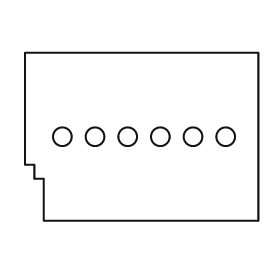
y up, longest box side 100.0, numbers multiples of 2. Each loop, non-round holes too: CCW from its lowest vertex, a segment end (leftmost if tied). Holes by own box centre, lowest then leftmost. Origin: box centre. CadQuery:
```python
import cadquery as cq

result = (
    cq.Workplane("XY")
    .moveTo(-42.0, -36.0)
    .lineTo(50.0, -36.0)
    .lineTo(50.0, 36.0)
    .lineTo(-50.0, 36.0)
    .lineTo(-50.0, -12.0)
    .lineTo(-46.0, -12.0)
    .lineTo(-46.0, -18.0)
    .lineTo(-42.0, -18.0)
    .close()
    .moveTo(-34.0, 0.0)
    .circle(4.0)
    .moveTo(-20.0, 0.0)
    .circle(4.0)
    .moveTo(-6.0, 0.0)
    .circle(4.0)
    .moveTo(8.0, 0.0)
    .circle(4.0)
    .moveTo(22.0, 0.0)
    .circle(4.0)
    .moveTo(36.0, 0.0)
    .circle(4.0)
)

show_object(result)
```